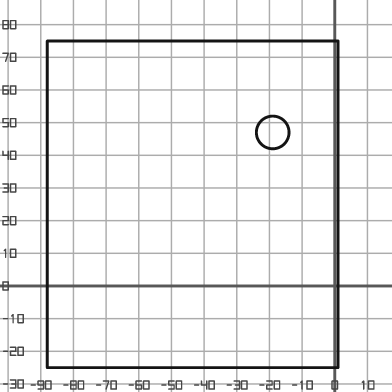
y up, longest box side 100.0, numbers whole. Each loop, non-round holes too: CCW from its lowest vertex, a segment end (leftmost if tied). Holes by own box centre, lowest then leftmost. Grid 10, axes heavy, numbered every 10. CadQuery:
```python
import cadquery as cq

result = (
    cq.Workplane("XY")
    .moveTo(-88.0, -25.0)
    .lineTo(1.0, -25.0)
    .lineTo(1.0, 75.0)
    .lineTo(-88.0, 75.0)
    .close()
    .moveTo(-19.0, 47.0)
    .circle(5.0)
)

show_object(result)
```